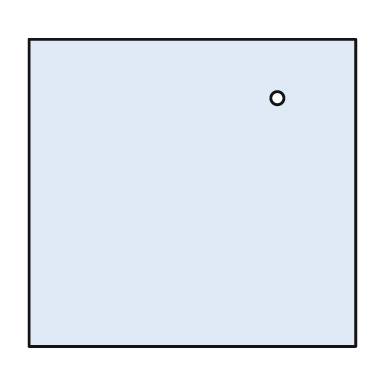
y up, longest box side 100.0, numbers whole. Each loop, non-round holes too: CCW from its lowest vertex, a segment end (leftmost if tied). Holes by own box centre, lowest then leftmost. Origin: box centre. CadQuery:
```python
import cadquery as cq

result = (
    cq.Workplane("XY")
    .moveTo(-50.0, -47.0)
    .lineTo(50.0, -47.0)
    .lineTo(50.0, 47.0)
    .lineTo(-50.0, 47.0)
    .close()
    .moveTo(26.0, 29.0)
    .circle(2.0)
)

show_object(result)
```